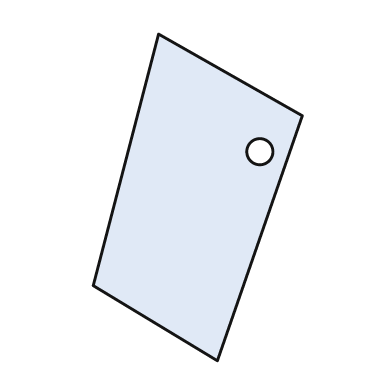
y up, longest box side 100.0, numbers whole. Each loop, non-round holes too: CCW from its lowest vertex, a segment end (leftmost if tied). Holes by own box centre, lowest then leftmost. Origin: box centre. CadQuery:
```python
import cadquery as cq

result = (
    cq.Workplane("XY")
    .moveTo(6.0, -50.0)
    .lineTo(32.0, 25.0)
    .lineTo(-12.0, 50.0)
    .lineTo(-32.0, -27.0)
    .close()
    .moveTo(19.0, 14.0)
    .circle(4.0)
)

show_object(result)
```